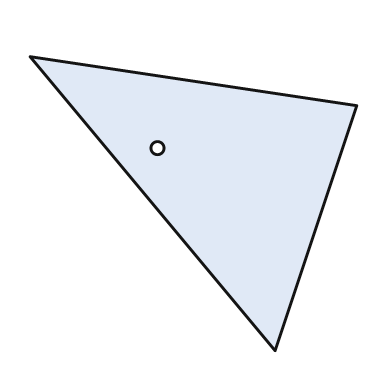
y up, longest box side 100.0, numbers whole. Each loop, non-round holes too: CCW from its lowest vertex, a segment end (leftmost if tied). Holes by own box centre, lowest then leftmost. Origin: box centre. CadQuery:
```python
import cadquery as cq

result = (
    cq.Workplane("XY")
    .moveTo(25.0, -45.0)
    .lineTo(50.0, 30.0)
    .lineTo(-50.0, 45.0)
    .close()
    .moveTo(-11.0, 17.0)
    .circle(2.0)
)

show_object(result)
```